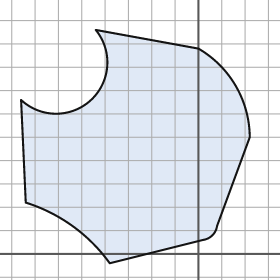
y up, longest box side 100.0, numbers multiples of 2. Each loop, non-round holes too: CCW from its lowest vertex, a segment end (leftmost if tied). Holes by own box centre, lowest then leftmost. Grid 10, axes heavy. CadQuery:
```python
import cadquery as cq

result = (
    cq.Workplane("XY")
    .moveTo(-38.0, -4.0)
    .lineTo(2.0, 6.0)
    .threePointArc((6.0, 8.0), (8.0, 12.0))
    .lineTo(22.0, 50.0)
    .threePointArc((16.0, 72.0), (0.0, 88.0))
    .lineTo(-44.0, 96.0)
    .threePointArc((-46.0, 66.0), (-76.0, 66.0))
    .lineTo(-74.0, 22.0)
    .threePointArc((-54.0, 12.0), (-38.0, -4.0))
    .close()
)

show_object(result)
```